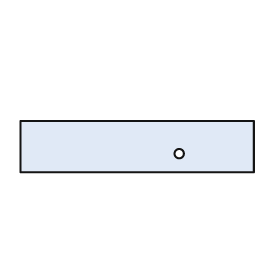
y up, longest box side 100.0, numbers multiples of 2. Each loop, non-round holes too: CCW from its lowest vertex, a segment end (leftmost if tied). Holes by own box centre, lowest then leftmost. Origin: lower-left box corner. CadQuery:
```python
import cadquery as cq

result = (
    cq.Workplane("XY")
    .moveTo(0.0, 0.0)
    .lineTo(100.0, 0.0)
    .lineTo(100.0, 22.0)
    .lineTo(0.0, 22.0)
    .close()
    .moveTo(68.0, 8.0)
    .circle(2.0)
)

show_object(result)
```